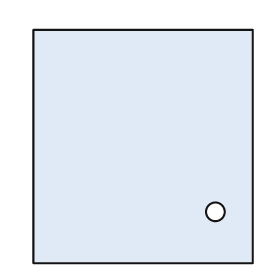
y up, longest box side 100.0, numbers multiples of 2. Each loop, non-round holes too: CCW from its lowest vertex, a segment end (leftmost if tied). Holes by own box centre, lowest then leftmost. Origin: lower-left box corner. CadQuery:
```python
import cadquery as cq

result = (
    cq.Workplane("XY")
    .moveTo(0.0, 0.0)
    .lineTo(94.0, 0.0)
    .lineTo(94.0, 100.0)
    .lineTo(0.0, 100.0)
    .close()
    .moveTo(78.0, 22.0)
    .circle(4.0)
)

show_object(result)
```